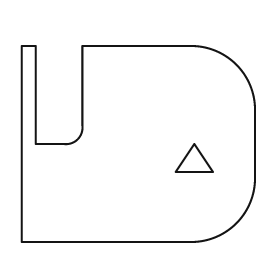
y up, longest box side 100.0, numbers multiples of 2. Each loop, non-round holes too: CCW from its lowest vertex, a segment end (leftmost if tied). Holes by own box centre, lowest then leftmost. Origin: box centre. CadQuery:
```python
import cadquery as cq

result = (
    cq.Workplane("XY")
    .moveTo(-50.0, -42.0)
    .lineTo(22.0, -42.0)
    .threePointArc((42.0, -34.0), (50.0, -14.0))
    .lineTo(50.0, 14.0)
    .threePointArc((42.0, 34.0), (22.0, 42.0))
    .lineTo(-24.0, 42.0)
    .lineTo(-24.0, 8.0)
    .threePointArc((-26.0, 2.0), (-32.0, 0.0))
    .lineTo(-44.0, 0.0)
    .lineTo(-44.0, 42.0)
    .lineTo(-50.0, 42.0)
    .close()
    .moveTo(16.0, -12.0)
    .lineTo(32.0, -12.0)
    .lineTo(24.0, 0.0)
    .close()
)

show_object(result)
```